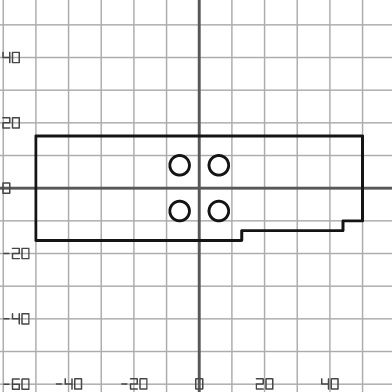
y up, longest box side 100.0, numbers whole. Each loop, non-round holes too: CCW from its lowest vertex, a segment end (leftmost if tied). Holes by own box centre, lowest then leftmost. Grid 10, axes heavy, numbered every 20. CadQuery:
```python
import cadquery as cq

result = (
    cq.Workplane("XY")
    .moveTo(-50.0, -16.0)
    .lineTo(13.0, -16.0)
    .lineTo(13.0, -13.0)
    .lineTo(44.0, -13.0)
    .lineTo(44.0, -10.0)
    .lineTo(50.0, -10.0)
    .lineTo(50.0, 16.0)
    .lineTo(-50.0, 16.0)
    .close()
    .moveTo(-6.0, -7.0)
    .circle(3.0)
    .moveTo(6.0, -7.0)
    .circle(3.0)
    .moveTo(-6.0, 7.0)
    .circle(3.0)
    .moveTo(6.0, 7.0)
    .circle(3.0)
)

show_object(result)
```